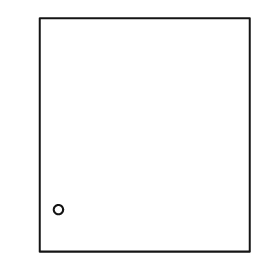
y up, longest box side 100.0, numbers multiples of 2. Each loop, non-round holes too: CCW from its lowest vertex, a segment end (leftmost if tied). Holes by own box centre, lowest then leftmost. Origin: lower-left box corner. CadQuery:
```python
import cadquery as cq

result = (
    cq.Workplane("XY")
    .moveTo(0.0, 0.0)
    .lineTo(90.0, 0.0)
    .lineTo(90.0, 100.0)
    .lineTo(0.0, 100.0)
    .close()
    .moveTo(8.0, 18.0)
    .circle(2.0)
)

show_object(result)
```